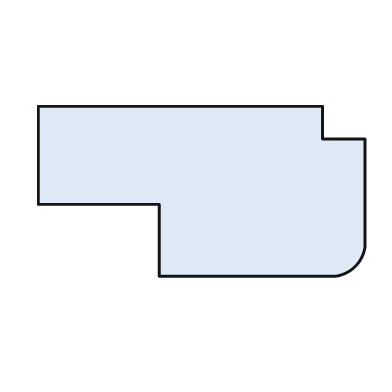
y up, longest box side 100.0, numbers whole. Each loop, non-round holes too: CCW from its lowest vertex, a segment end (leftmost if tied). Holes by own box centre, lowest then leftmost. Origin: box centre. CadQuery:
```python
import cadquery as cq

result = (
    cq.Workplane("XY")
    .moveTo(-13.0, -26.0)
    .lineTo(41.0, -26.0)
    .threePointArc((47.0, -23.0), (50.0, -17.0))
    .lineTo(50.0, 16.0)
    .lineTo(37.0, 16.0)
    .lineTo(37.0, 26.0)
    .lineTo(-50.0, 26.0)
    .lineTo(-50.0, -4.0)
    .lineTo(-13.0, -4.0)
    .close()
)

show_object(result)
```